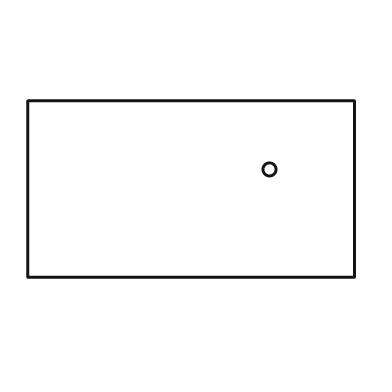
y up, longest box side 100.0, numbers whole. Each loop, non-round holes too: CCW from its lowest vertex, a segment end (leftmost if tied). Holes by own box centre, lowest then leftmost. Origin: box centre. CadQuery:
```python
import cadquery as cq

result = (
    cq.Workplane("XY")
    .moveTo(-50.0, -27.0)
    .lineTo(50.0, -27.0)
    .lineTo(50.0, 27.0)
    .lineTo(-50.0, 27.0)
    .close()
    .moveTo(24.0, 6.0)
    .circle(2.0)
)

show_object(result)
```